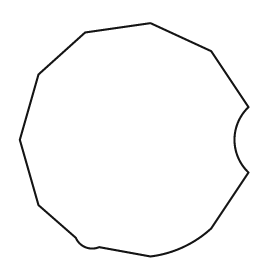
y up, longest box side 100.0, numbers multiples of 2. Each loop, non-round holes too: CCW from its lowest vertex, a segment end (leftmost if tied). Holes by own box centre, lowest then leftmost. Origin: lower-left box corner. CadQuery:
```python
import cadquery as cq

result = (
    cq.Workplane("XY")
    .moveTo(56.0, 0.0)
    .threePointArc((70.0, 4.0), (82.0, 12.0))
    .lineTo(98.0, 36.0)
    .threePointArc((92.0, 50.0), (98.0, 64.0))
    .lineTo(82.0, 88.0)
    .lineTo(56.0, 100.0)
    .lineTo(28.0, 96.0)
    .lineTo(8.0, 78.0)
    .lineTo(0.0, 50.0)
    .lineTo(8.0, 22.0)
    .lineTo(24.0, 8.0)
    .threePointArc((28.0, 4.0), (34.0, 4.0))
    .close()
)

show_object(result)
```